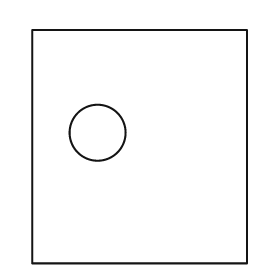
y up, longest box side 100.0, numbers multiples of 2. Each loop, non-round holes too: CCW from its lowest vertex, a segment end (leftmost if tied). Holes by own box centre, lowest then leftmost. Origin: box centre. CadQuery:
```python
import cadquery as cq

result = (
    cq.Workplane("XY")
    .moveTo(-46.0, -50.0)
    .lineTo(46.0, -50.0)
    .lineTo(46.0, 50.0)
    .lineTo(-46.0, 50.0)
    .close()
    .moveTo(-18.0, 6.0)
    .circle(12.0)
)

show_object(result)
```